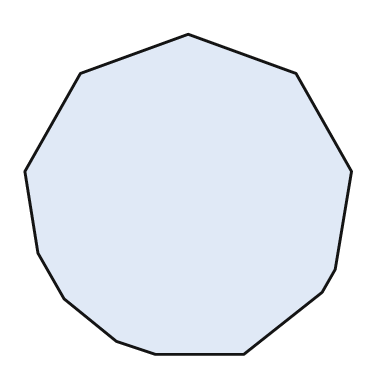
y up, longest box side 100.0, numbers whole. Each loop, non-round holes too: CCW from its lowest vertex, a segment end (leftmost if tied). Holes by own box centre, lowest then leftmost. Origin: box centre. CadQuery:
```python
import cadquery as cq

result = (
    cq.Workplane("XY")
    .moveTo(-10.0, -49.0)
    .lineTo(17.0, -49.0)
    .lineTo(41.0, -30.0)
    .lineTo(45.0, -23.0)
    .lineTo(50.0, 7.0)
    .lineTo(33.0, 37.0)
    .lineTo(0.0, 49.0)
    .lineTo(-33.0, 37.0)
    .lineTo(-50.0, 7.0)
    .lineTo(-46.0, -18.0)
    .lineTo(-38.0, -32.0)
    .lineTo(-22.0, -45.0)
    .close()
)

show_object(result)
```